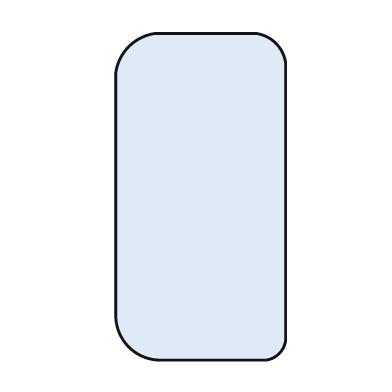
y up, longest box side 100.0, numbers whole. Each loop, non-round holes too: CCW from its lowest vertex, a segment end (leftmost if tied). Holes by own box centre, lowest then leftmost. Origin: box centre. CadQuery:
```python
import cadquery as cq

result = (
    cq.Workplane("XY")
    .moveTo(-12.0, -50.0)
    .lineTo(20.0, -50.0)
    .threePointArc((24.0, -48.0), (26.0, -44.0))
    .lineTo(26.0, 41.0)
    .threePointArc((23.0, 47.0), (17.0, 50.0))
    .lineTo(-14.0, 50.0)
    .threePointArc((-22.0, 46.0), (-26.0, 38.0))
    .lineTo(-26.0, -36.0)
    .threePointArc((-22.0, -46.0), (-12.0, -50.0))
    .close()
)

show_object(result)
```